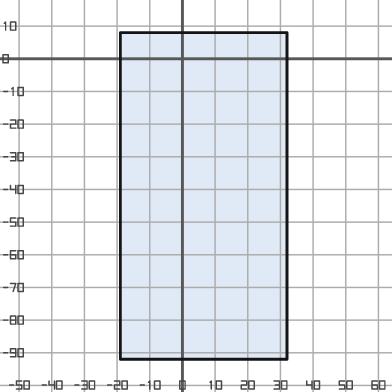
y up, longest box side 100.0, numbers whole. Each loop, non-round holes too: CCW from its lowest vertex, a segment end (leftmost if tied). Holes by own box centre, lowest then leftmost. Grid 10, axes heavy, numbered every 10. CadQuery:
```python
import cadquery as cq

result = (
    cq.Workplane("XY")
    .moveTo(-19.0, -92.0)
    .lineTo(32.0, -92.0)
    .lineTo(32.0, 8.0)
    .lineTo(-19.0, 8.0)
    .close()
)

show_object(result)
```